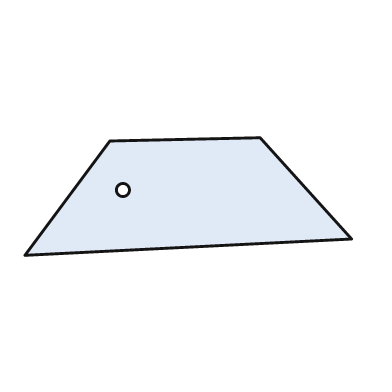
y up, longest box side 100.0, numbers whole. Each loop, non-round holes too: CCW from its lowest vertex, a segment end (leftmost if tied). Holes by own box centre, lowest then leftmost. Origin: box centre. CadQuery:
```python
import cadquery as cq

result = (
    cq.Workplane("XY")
    .moveTo(-50.0, -18.0)
    .lineTo(50.0, -13.0)
    .lineTo(22.0, 18.0)
    .lineTo(-24.0, 17.0)
    .close()
    .moveTo(-20.0, 2.0)
    .circle(2.0)
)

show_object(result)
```